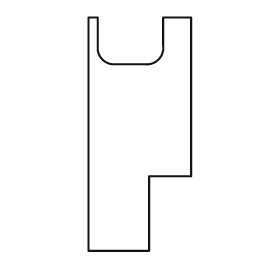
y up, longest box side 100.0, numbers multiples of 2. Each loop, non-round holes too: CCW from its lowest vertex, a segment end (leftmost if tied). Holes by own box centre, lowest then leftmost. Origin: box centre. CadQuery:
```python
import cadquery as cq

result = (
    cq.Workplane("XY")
    .moveTo(-22.0, -50.0)
    .lineTo(4.0, -50.0)
    .lineTo(4.0, -18.0)
    .lineTo(22.0, -18.0)
    .lineTo(22.0, 50.0)
    .lineTo(10.0, 50.0)
    .lineTo(10.0, 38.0)
    .threePointArc((8.0, 32.0), (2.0, 30.0))
    .lineTo(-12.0, 30.0)
    .threePointArc((-16.0, 32.0), (-18.0, 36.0))
    .lineTo(-18.0, 50.0)
    .lineTo(-22.0, 50.0)
    .close()
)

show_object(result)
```